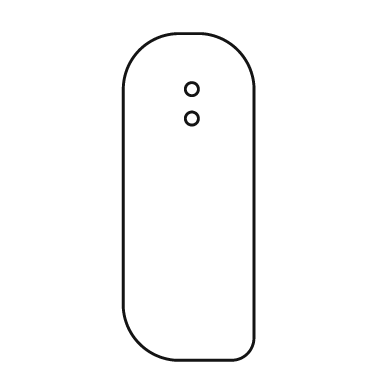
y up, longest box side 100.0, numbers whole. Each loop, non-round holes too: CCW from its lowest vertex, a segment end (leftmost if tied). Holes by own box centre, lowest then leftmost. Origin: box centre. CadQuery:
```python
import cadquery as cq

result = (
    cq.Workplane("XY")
    .moveTo(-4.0, -50.0)
    .lineTo(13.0, -50.0)
    .threePointArc((18.0, -48.0), (20.0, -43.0))
    .lineTo(20.0, 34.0)
    .threePointArc((15.0, 45.0), (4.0, 50.0))
    .lineTo(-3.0, 50.0)
    .threePointArc((-15.0, 45.0), (-20.0, 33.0))
    .lineTo(-20.0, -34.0)
    .threePointArc((-15.0, -45.0), (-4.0, -50.0))
    .close()
    .moveTo(1.0, 24.0)
    .circle(2.0)
    .moveTo(1.0, 33.0)
    .circle(2.0)
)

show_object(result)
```